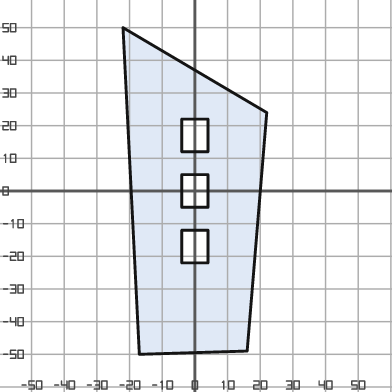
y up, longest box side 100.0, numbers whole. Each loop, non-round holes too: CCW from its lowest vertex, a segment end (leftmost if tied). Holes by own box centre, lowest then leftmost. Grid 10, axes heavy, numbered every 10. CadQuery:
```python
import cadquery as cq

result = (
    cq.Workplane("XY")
    .moveTo(-17.0, -50.0)
    .lineTo(16.0, -49.0)
    .lineTo(22.0, 24.0)
    .lineTo(-22.0, 50.0)
    .close()
    .moveTo(-4.0, -22.0)
    .lineTo(4.0, -22.0)
    .lineTo(4.0, -12.0)
    .lineTo(-4.0, -12.0)
    .close()
    .moveTo(-4.0, -5.0)
    .lineTo(4.0, -5.0)
    .lineTo(4.0, 5.0)
    .lineTo(-4.0, 5.0)
    .close()
    .moveTo(-4.0, 12.0)
    .lineTo(4.0, 12.0)
    .lineTo(4.0, 22.0)
    .lineTo(-4.0, 22.0)
    .close()
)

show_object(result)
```